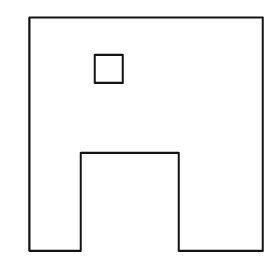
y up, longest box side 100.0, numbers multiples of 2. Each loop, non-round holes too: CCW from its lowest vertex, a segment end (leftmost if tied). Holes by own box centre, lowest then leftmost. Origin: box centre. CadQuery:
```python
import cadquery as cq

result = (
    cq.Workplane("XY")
    .moveTo(-50.0, -50.0)
    .lineTo(-28.0, -50.0)
    .lineTo(-28.0, -8.0)
    .lineTo(14.0, -8.0)
    .lineTo(14.0, -50.0)
    .lineTo(50.0, -50.0)
    .lineTo(50.0, 50.0)
    .lineTo(-50.0, 50.0)
    .close()
    .moveTo(-22.0, 22.0)
    .lineTo(-10.0, 22.0)
    .lineTo(-10.0, 34.0)
    .lineTo(-22.0, 34.0)
    .close()
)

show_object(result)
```